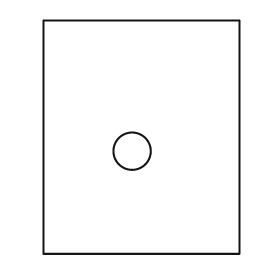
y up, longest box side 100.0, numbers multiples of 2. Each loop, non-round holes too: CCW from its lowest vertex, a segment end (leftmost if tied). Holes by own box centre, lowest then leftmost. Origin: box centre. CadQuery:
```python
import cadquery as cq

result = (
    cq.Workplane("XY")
    .moveTo(-42.0, -50.0)
    .lineTo(42.0, -50.0)
    .lineTo(42.0, 50.0)
    .lineTo(-42.0, 50.0)
    .close()
    .moveTo(-4.0, -6.0)
    .circle(8.0)
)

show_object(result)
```